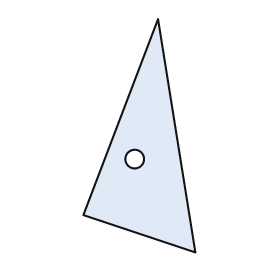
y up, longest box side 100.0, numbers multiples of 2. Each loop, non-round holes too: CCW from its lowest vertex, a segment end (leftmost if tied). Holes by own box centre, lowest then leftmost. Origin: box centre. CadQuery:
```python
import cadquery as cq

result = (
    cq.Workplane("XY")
    .moveTo(24.0, -50.0)
    .lineTo(8.0, 50.0)
    .lineTo(-24.0, -34.0)
    .close()
    .moveTo(-2.0, -10.0)
    .circle(4.0)
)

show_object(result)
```